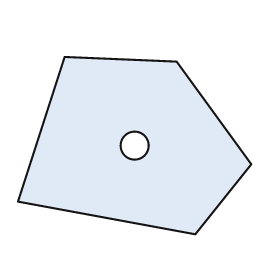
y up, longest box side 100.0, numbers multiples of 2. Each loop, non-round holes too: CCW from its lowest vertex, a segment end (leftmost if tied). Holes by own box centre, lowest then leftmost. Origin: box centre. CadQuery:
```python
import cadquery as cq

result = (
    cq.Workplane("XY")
    .moveTo(26.0, -38.0)
    .lineTo(50.0, -8.0)
    .lineTo(18.0, 36.0)
    .lineTo(-30.0, 38.0)
    .lineTo(-50.0, -24.0)
    .close()
    .moveTo(0.0, 0.0)
    .circle(6.0)
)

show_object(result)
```